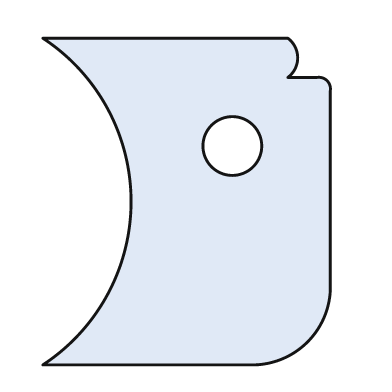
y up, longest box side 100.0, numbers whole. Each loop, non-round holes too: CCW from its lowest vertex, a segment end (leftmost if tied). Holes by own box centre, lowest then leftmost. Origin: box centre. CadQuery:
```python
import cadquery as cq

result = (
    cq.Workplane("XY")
    .moveTo(-44.0, -50.0)
    .lineTo(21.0, -50.0)
    .threePointArc((37.0, -43.0), (44.0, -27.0))
    .lineTo(44.0, 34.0)
    .threePointArc((43.0, 37.0), (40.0, 38.0))
    .lineTo(31.0, 38.0)
    .threePointArc((34.0, 44.0), (31.0, 50.0))
    .lineTo(-44.0, 50.0)
    .threePointArc((-17.0, 0.0), (-44.0, -50.0))
    .close()
    .moveTo(14.0, 17.0)
    .circle(9.0)
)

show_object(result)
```